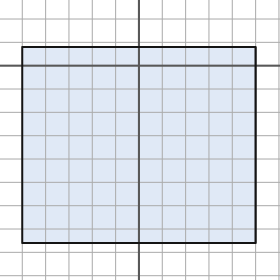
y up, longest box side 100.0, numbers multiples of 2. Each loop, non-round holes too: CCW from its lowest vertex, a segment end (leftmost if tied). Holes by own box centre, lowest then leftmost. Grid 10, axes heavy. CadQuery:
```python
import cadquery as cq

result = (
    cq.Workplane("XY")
    .moveTo(-50.0, -76.0)
    .lineTo(50.0, -76.0)
    .lineTo(50.0, 8.0)
    .lineTo(-50.0, 8.0)
    .close()
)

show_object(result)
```